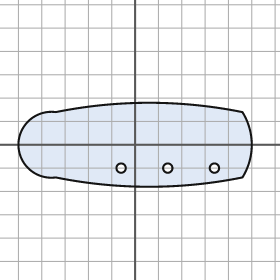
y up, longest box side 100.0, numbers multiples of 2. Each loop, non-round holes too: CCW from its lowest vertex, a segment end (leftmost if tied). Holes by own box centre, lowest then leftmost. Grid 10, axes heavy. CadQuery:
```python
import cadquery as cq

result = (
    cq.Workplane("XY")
    .moveTo(-34.0, -14.0)
    .threePointArc((6.0, -18.0), (46.0, -14.0))
    .threePointArc((50.0, 0.0), (46.0, 14.0))
    .threePointArc((6.0, 18.0), (-34.0, 14.0))
    .threePointArc((-50.0, 0.0), (-34.0, -14.0))
    .close()
    .moveTo(-6.0, -10.0)
    .circle(2.0)
    .moveTo(14.0, -10.0)
    .circle(2.0)
    .moveTo(34.0, -10.0)
    .circle(2.0)
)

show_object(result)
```